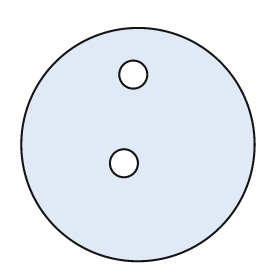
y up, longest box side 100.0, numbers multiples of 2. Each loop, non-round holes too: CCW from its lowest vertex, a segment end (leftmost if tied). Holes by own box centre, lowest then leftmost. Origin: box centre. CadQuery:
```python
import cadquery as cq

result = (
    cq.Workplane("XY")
    .moveTo(0.0, 0.0)
    .circle(50.0)
    .moveTo(-6.0, -8.0)
    .circle(6.0)
    .moveTo(-2.0, 30.0)
    .circle(6.0)
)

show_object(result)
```